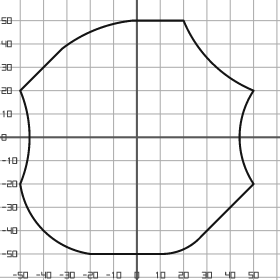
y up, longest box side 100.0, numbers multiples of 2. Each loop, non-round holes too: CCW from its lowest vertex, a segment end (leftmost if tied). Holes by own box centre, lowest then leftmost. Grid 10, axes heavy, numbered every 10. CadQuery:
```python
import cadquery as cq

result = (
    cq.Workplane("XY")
    .moveTo(-20.0, -50.0)
    .lineTo(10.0, -50.0)
    .threePointArc((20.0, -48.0), (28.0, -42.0))
    .lineTo(50.0, -20.0)
    .threePointArc((44.0, 0.0), (50.0, 20.0))
    .threePointArc((32.0, 32.0), (20.0, 50.0))
    .lineTo(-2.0, 50.0)
    .threePointArc((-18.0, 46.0), (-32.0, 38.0))
    .lineTo(-50.0, 20.0)
    .threePointArc((-46.0, 0.0), (-50.0, -20.0))
    .threePointArc((-40.0, -40.0), (-20.0, -50.0))
    .close()
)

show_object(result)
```